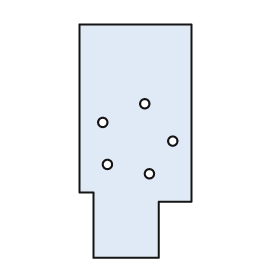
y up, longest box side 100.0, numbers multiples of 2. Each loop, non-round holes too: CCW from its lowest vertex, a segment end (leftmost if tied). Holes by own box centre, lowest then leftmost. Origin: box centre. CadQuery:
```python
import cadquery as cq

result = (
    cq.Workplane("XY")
    .moveTo(-18.0, -50.0)
    .lineTo(10.0, -50.0)
    .lineTo(10.0, -26.0)
    .lineTo(24.0, -26.0)
    .lineTo(24.0, 50.0)
    .lineTo(-24.0, 50.0)
    .lineTo(-24.0, -22.0)
    .lineTo(-18.0, -22.0)
    .close()
    .moveTo(6.0, -14.0)
    .circle(2.0)
    .moveTo(-12.0, -10.0)
    .circle(2.0)
    .moveTo(16.0, 0.0)
    .circle(2.0)
    .moveTo(-14.0, 8.0)
    .circle(2.0)
    .moveTo(4.0, 16.0)
    .circle(2.0)
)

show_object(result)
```